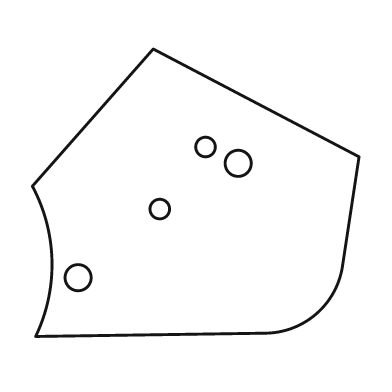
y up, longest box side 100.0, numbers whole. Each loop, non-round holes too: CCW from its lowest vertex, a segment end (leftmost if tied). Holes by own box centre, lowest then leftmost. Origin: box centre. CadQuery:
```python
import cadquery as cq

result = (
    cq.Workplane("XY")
    .moveTo(-49.0, -44.0)
    .lineTo(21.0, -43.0)
    .threePointArc((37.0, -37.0), (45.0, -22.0))
    .lineTo(50.0, 11.0)
    .lineTo(-13.0, 44.0)
    .lineTo(-50.0, 2.0)
    .threePointArc((-44.0, -21.0), (-49.0, -44.0))
    .close()
    .moveTo(-36.0, -26.0)
    .circle(4.0)
    .moveTo(-11.0, -5.0)
    .circle(3.0)
    .moveTo(13.0, 9.0)
    .circle(4.0)
    .moveTo(3.0, 14.0)
    .circle(3.0)
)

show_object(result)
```